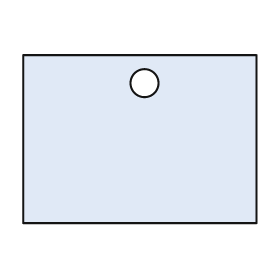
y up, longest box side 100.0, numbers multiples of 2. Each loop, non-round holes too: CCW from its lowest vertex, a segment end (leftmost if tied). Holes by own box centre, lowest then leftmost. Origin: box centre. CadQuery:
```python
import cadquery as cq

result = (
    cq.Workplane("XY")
    .moveTo(-50.0, -36.0)
    .lineTo(50.0, -36.0)
    .lineTo(50.0, 36.0)
    .lineTo(-50.0, 36.0)
    .close()
    .moveTo(2.0, 24.0)
    .circle(6.0)
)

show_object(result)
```